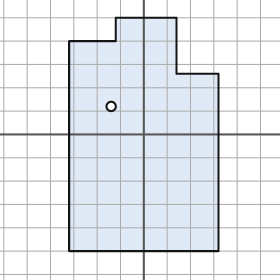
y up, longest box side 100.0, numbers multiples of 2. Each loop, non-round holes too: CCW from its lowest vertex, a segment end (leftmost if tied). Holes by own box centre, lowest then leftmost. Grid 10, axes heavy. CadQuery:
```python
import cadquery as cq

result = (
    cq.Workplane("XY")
    .moveTo(-32.0, -50.0)
    .lineTo(32.0, -50.0)
    .lineTo(32.0, 26.0)
    .lineTo(14.0, 26.0)
    .lineTo(14.0, 50.0)
    .lineTo(-12.0, 50.0)
    .lineTo(-12.0, 40.0)
    .lineTo(-32.0, 40.0)
    .close()
    .moveTo(-14.0, 12.0)
    .circle(2.0)
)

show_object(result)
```